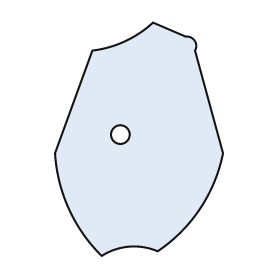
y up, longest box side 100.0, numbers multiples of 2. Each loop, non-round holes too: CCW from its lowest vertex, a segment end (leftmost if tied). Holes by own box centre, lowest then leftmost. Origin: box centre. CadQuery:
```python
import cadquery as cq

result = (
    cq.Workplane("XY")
    .moveTo(-16.0, -50.0)
    .threePointArc((-4.0, -46.0), (8.0, -48.0))
    .threePointArc((26.0, -30.0), (36.0, -6.0))
    .lineTo(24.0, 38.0)
    .threePointArc((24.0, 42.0), (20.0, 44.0))
    .lineTo(6.0, 50.0)
    .threePointArc((-6.0, 42.0), (-20.0, 38.0))
    .lineTo(-36.0, -6.0)
    .threePointArc((-30.0, -30.0), (-16.0, -50.0))
    .close()
    .moveTo(-8.0, 2.0)
    .circle(4.0)
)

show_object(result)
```